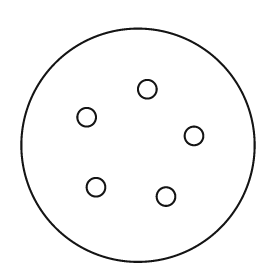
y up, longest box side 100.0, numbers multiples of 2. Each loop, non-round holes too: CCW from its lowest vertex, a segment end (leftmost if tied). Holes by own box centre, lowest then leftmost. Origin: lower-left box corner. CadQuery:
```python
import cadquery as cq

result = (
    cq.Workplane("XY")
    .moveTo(50.0, 50.0)
    .circle(50.0)
    .moveTo(62.0, 28.0)
    .circle(4.0)
    .moveTo(32.0, 32.0)
    .circle(4.0)
    .moveTo(74.0, 54.0)
    .circle(4.0)
    .moveTo(28.0, 62.0)
    .circle(4.0)
    .moveTo(54.0, 74.0)
    .circle(4.0)
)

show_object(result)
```